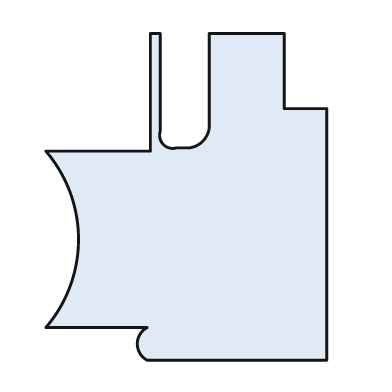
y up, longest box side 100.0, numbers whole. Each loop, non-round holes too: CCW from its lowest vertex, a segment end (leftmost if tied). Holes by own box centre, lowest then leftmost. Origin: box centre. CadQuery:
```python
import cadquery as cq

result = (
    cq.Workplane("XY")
    .moveTo(-12.0, -50.0)
    .lineTo(43.0, -50.0)
    .lineTo(43.0, 27.0)
    .lineTo(30.0, 27.0)
    .lineTo(30.0, 50.0)
    .lineTo(7.0, 50.0)
    .lineTo(7.0, 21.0)
    .threePointArc((5.0, 17.0), (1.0, 15.0))
    .lineTo(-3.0, 15.0)
    .threePointArc((-7.0, 16.0), (-8.0, 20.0))
    .lineTo(-8.0, 50.0)
    .lineTo(-11.0, 50.0)
    .lineTo(-11.0, 14.0)
    .lineTo(-43.0, 14.0)
    .threePointArc((-33.0, -13.0), (-43.0, -40.0))
    .lineTo(-12.0, -40.0)
    .threePointArc((-15.0, -45.0), (-12.0, -50.0))
    .close()
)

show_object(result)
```